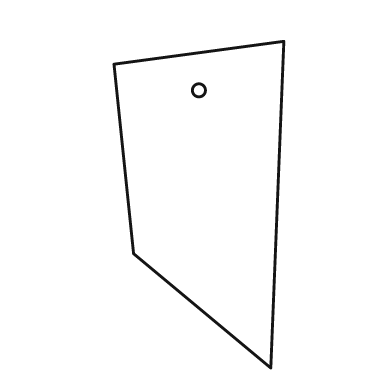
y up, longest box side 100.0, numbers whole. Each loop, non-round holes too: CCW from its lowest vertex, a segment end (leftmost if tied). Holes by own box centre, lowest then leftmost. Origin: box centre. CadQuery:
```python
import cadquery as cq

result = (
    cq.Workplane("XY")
    .moveTo(22.0, -50.0)
    .lineTo(26.0, 50.0)
    .lineTo(-26.0, 43.0)
    .lineTo(-20.0, -15.0)
    .close()
    .moveTo(0.0, 35.0)
    .circle(2.0)
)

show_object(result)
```